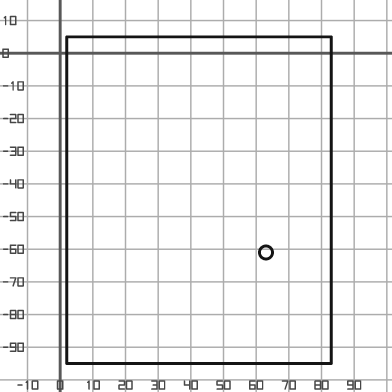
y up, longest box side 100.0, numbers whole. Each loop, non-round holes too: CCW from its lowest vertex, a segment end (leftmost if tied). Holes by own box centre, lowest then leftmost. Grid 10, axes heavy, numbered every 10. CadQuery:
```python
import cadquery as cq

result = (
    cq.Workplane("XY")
    .moveTo(2.0, -95.0)
    .lineTo(83.0, -95.0)
    .lineTo(83.0, 5.0)
    .lineTo(2.0, 5.0)
    .close()
    .moveTo(63.0, -61.0)
    .circle(2.0)
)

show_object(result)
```